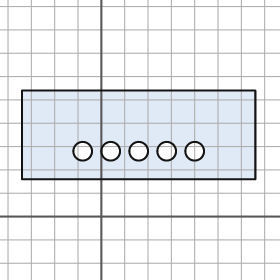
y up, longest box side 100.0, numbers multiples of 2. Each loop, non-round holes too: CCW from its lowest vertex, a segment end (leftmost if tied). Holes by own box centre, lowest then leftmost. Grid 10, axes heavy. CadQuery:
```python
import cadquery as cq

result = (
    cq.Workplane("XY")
    .moveTo(-34.0, 16.0)
    .lineTo(66.0, 16.0)
    .lineTo(66.0, 54.0)
    .lineTo(-34.0, 54.0)
    .close()
    .moveTo(-8.0, 28.0)
    .circle(4.0)
    .moveTo(4.0, 28.0)
    .circle(4.0)
    .moveTo(16.0, 28.0)
    .circle(4.0)
    .moveTo(28.0, 28.0)
    .circle(4.0)
    .moveTo(40.0, 28.0)
    .circle(4.0)
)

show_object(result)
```